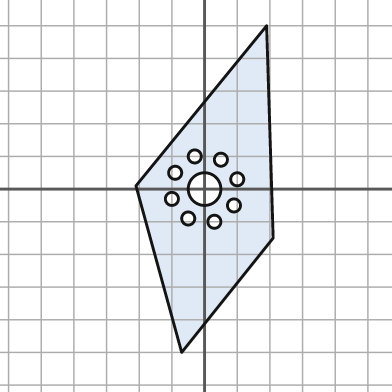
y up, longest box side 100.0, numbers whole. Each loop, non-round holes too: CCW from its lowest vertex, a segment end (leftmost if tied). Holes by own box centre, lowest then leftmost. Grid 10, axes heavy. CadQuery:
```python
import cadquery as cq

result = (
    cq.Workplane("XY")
    .moveTo(-7.0, -50.0)
    .lineTo(21.0, -15.0)
    .lineTo(19.0, 50.0)
    .lineTo(-21.0, 1.0)
    .close()
    .moveTo(3.0, -10.0)
    .circle(2.0)
    .moveTo(-5.0, -9.0)
    .circle(2.0)
    .moveTo(9.0, -5.0)
    .circle(2.0)
    .moveTo(-10.0, -3.0)
    .circle(2.0)
    .moveTo(0.0, 0.0)
    .circle(5.0)
    .moveTo(10.0, 3.0)
    .circle(2.0)
    .moveTo(-9.0, 5.0)
    .circle(2.0)
    .moveTo(5.0, 9.0)
    .circle(2.0)
    .moveTo(-3.0, 10.0)
    .circle(2.0)
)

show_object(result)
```